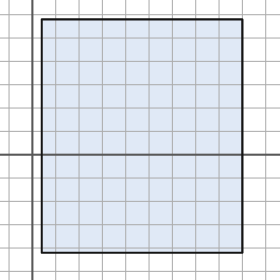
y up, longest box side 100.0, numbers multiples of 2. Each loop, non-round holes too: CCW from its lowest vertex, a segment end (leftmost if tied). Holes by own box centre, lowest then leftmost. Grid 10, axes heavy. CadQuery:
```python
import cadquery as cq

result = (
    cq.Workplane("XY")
    .moveTo(4.0, -42.0)
    .lineTo(90.0, -42.0)
    .lineTo(90.0, 58.0)
    .lineTo(4.0, 58.0)
    .close()
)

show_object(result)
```